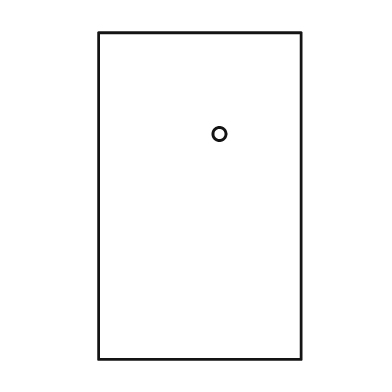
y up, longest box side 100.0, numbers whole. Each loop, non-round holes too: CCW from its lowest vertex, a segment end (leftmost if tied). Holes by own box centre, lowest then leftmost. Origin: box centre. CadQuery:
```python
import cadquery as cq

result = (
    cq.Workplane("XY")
    .moveTo(-31.0, -50.0)
    .lineTo(31.0, -50.0)
    .lineTo(31.0, 50.0)
    .lineTo(-31.0, 50.0)
    .close()
    .moveTo(6.0, 19.0)
    .circle(2.0)
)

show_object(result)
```